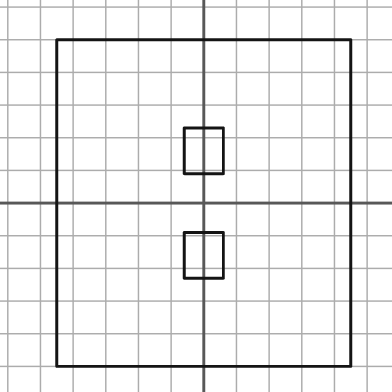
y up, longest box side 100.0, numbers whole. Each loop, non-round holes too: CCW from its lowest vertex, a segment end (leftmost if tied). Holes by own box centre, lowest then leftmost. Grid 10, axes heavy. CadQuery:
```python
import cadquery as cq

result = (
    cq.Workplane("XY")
    .moveTo(-45.0, -50.0)
    .lineTo(45.0, -50.0)
    .lineTo(45.0, 50.0)
    .lineTo(-45.0, 50.0)
    .close()
    .moveTo(-6.0, -23.0)
    .lineTo(6.0, -23.0)
    .lineTo(6.0, -9.0)
    .lineTo(-6.0, -9.0)
    .close()
    .moveTo(-6.0, 9.0)
    .lineTo(6.0, 9.0)
    .lineTo(6.0, 23.0)
    .lineTo(-6.0, 23.0)
    .close()
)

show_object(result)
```